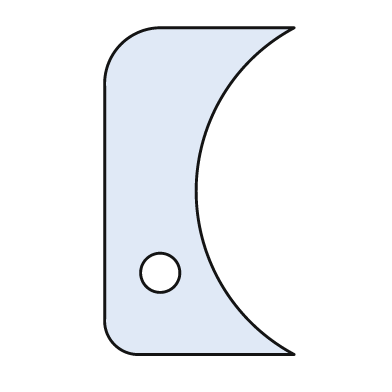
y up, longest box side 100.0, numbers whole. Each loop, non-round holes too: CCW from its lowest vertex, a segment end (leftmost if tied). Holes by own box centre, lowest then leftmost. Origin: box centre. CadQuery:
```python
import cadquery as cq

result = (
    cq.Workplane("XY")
    .moveTo(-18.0, -50.0)
    .lineTo(29.0, -50.0)
    .threePointArc((-1.0, 0.0), (29.0, 50.0))
    .lineTo(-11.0, 50.0)
    .threePointArc((-24.0, 45.0), (-29.0, 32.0))
    .lineTo(-29.0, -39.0)
    .threePointArc((-26.0, -47.0), (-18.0, -50.0))
    .close()
    .moveTo(-12.0, -25.0)
    .circle(6.0)
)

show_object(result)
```